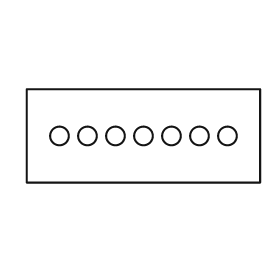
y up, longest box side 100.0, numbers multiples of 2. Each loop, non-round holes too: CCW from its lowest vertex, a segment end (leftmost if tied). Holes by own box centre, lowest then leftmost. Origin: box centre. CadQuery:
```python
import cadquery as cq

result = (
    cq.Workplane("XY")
    .moveTo(-50.0, -20.0)
    .lineTo(50.0, -20.0)
    .lineTo(50.0, 20.0)
    .lineTo(-50.0, 20.0)
    .close()
    .moveTo(-36.0, 0.0)
    .circle(4.0)
    .moveTo(-24.0, 0.0)
    .circle(4.0)
    .moveTo(-12.0, 0.0)
    .circle(4.0)
    .moveTo(0.0, 0.0)
    .circle(4.0)
    .moveTo(12.0, 0.0)
    .circle(4.0)
    .moveTo(24.0, 0.0)
    .circle(4.0)
    .moveTo(36.0, 0.0)
    .circle(4.0)
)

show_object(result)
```